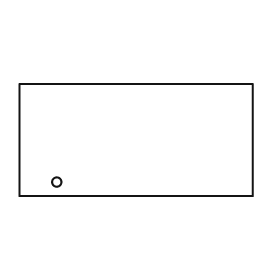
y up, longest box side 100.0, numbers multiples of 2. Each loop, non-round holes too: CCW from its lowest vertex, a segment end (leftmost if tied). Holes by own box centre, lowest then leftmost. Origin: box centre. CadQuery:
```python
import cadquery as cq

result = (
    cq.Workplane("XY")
    .moveTo(-50.0, -24.0)
    .lineTo(50.0, -24.0)
    .lineTo(50.0, 24.0)
    .lineTo(-50.0, 24.0)
    .close()
    .moveTo(-34.0, -18.0)
    .circle(2.0)
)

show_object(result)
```